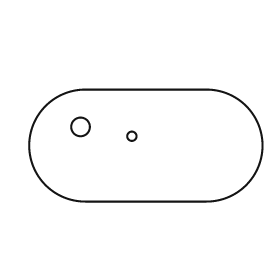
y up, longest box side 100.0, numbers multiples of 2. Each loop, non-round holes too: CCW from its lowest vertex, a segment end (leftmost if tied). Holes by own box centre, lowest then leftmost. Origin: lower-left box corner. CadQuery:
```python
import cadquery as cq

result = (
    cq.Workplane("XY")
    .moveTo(24.0, 0.0)
    .lineTo(76.0, 0.0)
    .threePointArc((100.0, 24.0), (76.0, 48.0))
    .lineTo(24.0, 48.0)
    .threePointArc((0.0, 24.0), (24.0, 0.0))
    .close()
    .moveTo(44.0, 28.0)
    .circle(2.0)
    .moveTo(22.0, 32.0)
    .circle(4.0)
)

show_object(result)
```